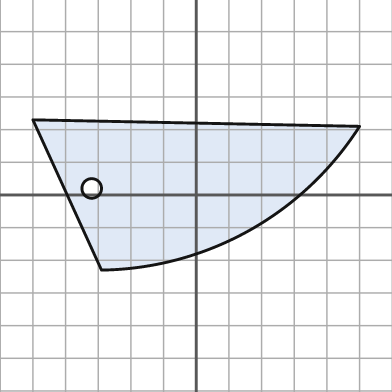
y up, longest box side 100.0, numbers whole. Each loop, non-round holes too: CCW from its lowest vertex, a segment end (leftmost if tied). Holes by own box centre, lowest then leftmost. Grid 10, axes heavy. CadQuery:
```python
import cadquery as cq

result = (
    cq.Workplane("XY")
    .moveTo(-29.0, -23.0)
    .threePointArc((16.0, -11.0), (50.0, 21.0))
    .lineTo(-50.0, 23.0)
    .close()
    .moveTo(-32.0, 2.0)
    .circle(3.0)
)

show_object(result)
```